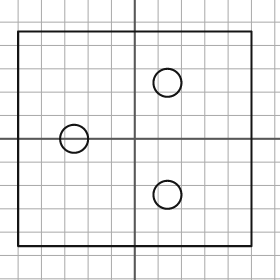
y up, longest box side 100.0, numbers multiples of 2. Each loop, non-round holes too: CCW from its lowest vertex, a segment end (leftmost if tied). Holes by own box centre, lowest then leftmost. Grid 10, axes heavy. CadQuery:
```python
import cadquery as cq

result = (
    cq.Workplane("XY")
    .moveTo(-50.0, -46.0)
    .lineTo(50.0, -46.0)
    .lineTo(50.0, 46.0)
    .lineTo(-50.0, 46.0)
    .close()
    .moveTo(14.0, -24.0)
    .circle(6.0)
    .moveTo(-26.0, 0.0)
    .circle(6.0)
    .moveTo(14.0, 24.0)
    .circle(6.0)
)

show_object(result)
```